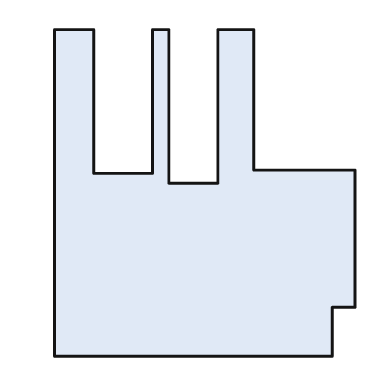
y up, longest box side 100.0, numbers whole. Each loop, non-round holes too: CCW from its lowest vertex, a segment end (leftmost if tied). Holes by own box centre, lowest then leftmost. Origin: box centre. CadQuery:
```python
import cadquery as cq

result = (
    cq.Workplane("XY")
    .moveTo(-46.0, -50.0)
    .lineTo(39.0, -50.0)
    .lineTo(39.0, -35.0)
    .lineTo(46.0, -35.0)
    .lineTo(46.0, 7.0)
    .lineTo(15.0, 7.0)
    .lineTo(15.0, 50.0)
    .lineTo(4.0, 50.0)
    .lineTo(4.0, 3.0)
    .lineTo(-11.0, 3.0)
    .lineTo(-11.0, 50.0)
    .lineTo(-16.0, 50.0)
    .lineTo(-16.0, 6.0)
    .lineTo(-34.0, 6.0)
    .lineTo(-34.0, 50.0)
    .lineTo(-46.0, 50.0)
    .close()
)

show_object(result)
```